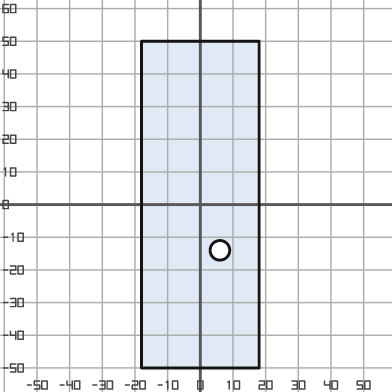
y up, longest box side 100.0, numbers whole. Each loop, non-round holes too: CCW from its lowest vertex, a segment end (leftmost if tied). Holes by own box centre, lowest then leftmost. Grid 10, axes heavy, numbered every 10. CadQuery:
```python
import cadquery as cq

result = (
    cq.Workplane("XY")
    .moveTo(-18.0, -50.0)
    .lineTo(18.0, -50.0)
    .lineTo(18.0, 50.0)
    .lineTo(-18.0, 50.0)
    .close()
    .moveTo(6.0, -14.0)
    .circle(3.0)
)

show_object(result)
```